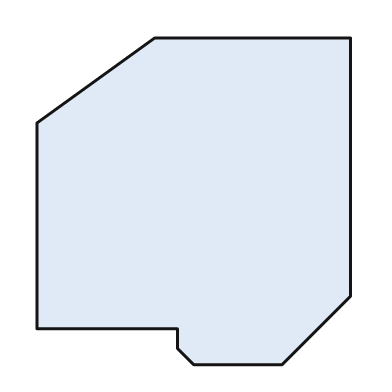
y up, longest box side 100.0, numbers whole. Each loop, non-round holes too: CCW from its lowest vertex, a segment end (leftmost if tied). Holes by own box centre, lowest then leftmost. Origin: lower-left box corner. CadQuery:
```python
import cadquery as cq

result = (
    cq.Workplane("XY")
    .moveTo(48.0, 0.0)
    .lineTo(75.0, 0.0)
    .lineTo(96.0, 21.0)
    .lineTo(96.0, 100.0)
    .lineTo(36.0, 100.0)
    .lineTo(0.0, 74.0)
    .lineTo(0.0, 11.0)
    .lineTo(43.0, 11.0)
    .lineTo(43.0, 5.0)
    .close()
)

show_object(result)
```